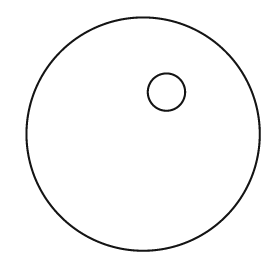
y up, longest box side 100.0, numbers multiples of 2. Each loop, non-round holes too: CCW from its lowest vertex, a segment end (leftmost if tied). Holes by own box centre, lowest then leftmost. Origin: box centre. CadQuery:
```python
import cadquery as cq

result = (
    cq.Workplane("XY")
    .moveTo(0.0, 0.0)
    .circle(50.0)
    .moveTo(10.0, 18.0)
    .circle(8.0)
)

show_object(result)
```